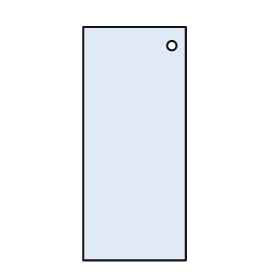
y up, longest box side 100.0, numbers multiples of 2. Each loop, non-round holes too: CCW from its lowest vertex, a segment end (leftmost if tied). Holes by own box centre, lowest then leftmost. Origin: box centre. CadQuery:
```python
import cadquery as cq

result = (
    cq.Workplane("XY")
    .moveTo(-22.0, -50.0)
    .lineTo(22.0, -50.0)
    .lineTo(22.0, 50.0)
    .lineTo(-22.0, 50.0)
    .close()
    .moveTo(16.0, 42.0)
    .circle(2.0)
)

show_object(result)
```